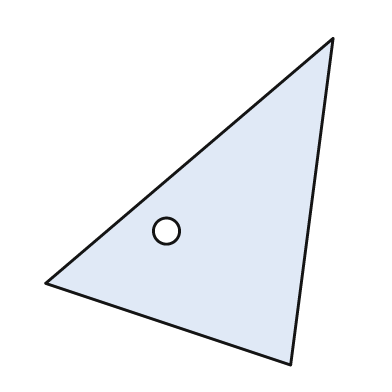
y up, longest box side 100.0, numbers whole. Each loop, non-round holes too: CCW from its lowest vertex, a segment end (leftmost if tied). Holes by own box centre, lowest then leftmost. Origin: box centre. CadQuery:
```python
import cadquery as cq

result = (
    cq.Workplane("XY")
    .moveTo(31.0, -50.0)
    .lineTo(44.0, 50.0)
    .lineTo(-44.0, -25.0)
    .close()
    .moveTo(-7.0, -9.0)
    .circle(4.0)
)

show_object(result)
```